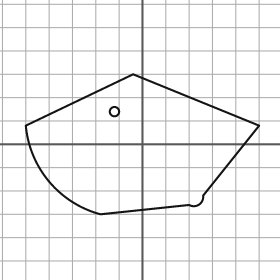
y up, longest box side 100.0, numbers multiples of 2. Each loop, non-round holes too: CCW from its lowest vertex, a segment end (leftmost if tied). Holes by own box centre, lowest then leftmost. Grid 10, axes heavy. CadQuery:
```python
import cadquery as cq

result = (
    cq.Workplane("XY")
    .moveTo(-18.0, -30.0)
    .lineTo(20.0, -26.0)
    .threePointArc((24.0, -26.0), (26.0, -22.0))
    .lineTo(50.0, 8.0)
    .lineTo(-4.0, 30.0)
    .lineTo(-50.0, 8.0)
    .threePointArc((-40.0, -16.0), (-18.0, -30.0))
    .close()
    .moveTo(-12.0, 14.0)
    .circle(2.0)
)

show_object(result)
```